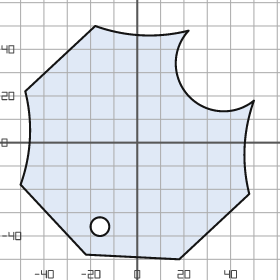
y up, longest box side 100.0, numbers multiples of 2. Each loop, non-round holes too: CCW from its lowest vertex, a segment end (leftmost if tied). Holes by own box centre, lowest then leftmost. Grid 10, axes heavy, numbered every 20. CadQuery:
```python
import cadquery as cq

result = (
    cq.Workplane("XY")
    .moveTo(18.0, -50.0)
    .lineTo(48.0, -22.0)
    .threePointArc((46.0, -2.0), (50.0, 18.0))
    .threePointArc((22.0, 20.0), (22.0, 48.0))
    .threePointArc((2.0, 46.0), (-18.0, 50.0))
    .lineTo(-48.0, 22.0)
    .threePointArc((-46.0, 2.0), (-50.0, -18.0))
    .lineTo(-22.0, -48.0)
    .close()
    .moveTo(-16.0, -36.0)
    .circle(4.0)
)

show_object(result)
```